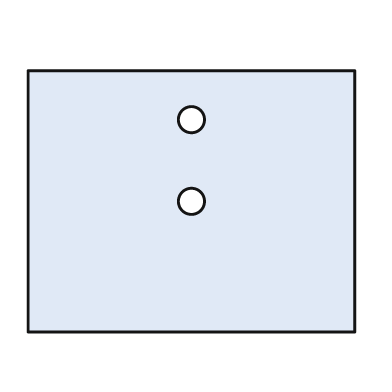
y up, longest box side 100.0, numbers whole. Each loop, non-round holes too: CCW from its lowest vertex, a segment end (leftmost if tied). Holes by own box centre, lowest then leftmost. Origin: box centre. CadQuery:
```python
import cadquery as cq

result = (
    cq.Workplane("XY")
    .moveTo(-50.0, -40.0)
    .lineTo(50.0, -40.0)
    .lineTo(50.0, 40.0)
    .lineTo(-50.0, 40.0)
    .close()
    .moveTo(0.0, 0.0)
    .circle(4.0)
    .moveTo(0.0, 25.0)
    .circle(4.0)
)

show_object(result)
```